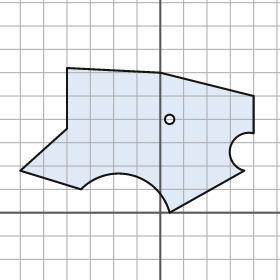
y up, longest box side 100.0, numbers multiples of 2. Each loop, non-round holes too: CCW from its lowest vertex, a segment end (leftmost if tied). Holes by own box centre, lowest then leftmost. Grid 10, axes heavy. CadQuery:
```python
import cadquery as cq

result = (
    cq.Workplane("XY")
    .moveTo(4.0, 0.0)
    .lineTo(36.0, 18.0)
    .threePointArc((30.0, 28.0), (40.0, 34.0))
    .lineTo(40.0, 50.0)
    .lineTo(0.0, 60.0)
    .lineTo(-40.0, 62.0)
    .lineTo(-40.0, 36.0)
    .lineTo(-60.0, 18.0)
    .lineTo(-34.0, 10.0)
    .threePointArc((-12.0, 16.0), (4.0, 0.0))
    .close()
    .moveTo(4.0, 40.0)
    .circle(2.0)
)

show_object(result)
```